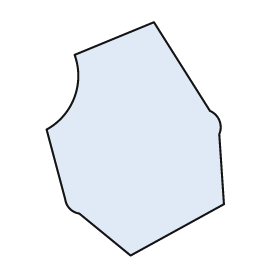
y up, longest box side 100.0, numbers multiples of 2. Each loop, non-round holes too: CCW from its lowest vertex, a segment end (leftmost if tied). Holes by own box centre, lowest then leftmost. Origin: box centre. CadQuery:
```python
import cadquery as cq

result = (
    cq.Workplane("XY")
    .moveTo(-2.0, -50.0)
    .lineTo(38.0, -28.0)
    .lineTo(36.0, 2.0)
    .threePointArc((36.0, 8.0), (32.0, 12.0))
    .lineTo(8.0, 50.0)
    .lineTo(-26.0, 36.0)
    .threePointArc((-26.0, 18.0), (-38.0, 4.0))
    .lineTo(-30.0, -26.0)
    .threePointArc((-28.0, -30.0), (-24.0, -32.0))
    .close()
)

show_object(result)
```